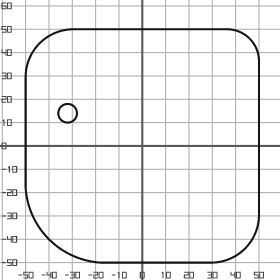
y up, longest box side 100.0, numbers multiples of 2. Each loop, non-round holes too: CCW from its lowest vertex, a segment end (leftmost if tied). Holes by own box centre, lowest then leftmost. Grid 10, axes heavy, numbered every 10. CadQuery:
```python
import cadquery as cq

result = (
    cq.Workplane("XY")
    .moveTo(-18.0, -50.0)
    .lineTo(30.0, -50.0)
    .threePointArc((44.0, -44.0), (50.0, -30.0))
    .lineTo(50.0, 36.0)
    .threePointArc((46.0, 46.0), (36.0, 50.0))
    .lineTo(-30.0, 50.0)
    .threePointArc((-44.0, 44.0), (-50.0, 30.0))
    .lineTo(-50.0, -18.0)
    .threePointArc((-40.0, -40.0), (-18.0, -50.0))
    .close()
    .moveTo(-32.0, 14.0)
    .circle(4.0)
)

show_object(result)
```